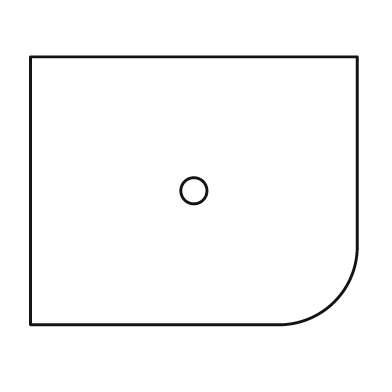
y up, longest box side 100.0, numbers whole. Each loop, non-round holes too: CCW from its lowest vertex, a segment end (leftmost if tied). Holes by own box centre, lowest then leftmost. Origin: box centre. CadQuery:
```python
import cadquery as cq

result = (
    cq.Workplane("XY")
    .moveTo(-50.0, -41.0)
    .lineTo(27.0, -41.0)
    .threePointArc((43.0, -34.0), (50.0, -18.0))
    .lineTo(50.0, 41.0)
    .lineTo(-50.0, 41.0)
    .close()
    .moveTo(0.0, 0.0)
    .circle(4.0)
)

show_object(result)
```